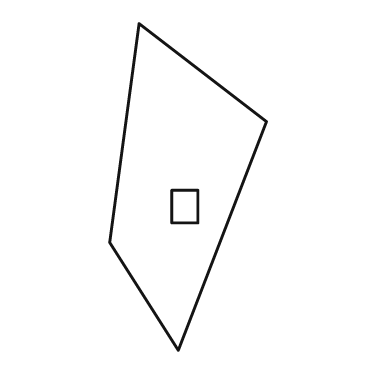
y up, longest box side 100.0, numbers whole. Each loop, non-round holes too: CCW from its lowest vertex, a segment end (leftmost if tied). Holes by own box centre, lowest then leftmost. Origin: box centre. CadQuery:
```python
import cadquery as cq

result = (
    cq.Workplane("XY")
    .moveTo(-3.0, -50.0)
    .lineTo(24.0, 20.0)
    .lineTo(-15.0, 50.0)
    .lineTo(-24.0, -17.0)
    .close()
    .moveTo(-5.0, -11.0)
    .lineTo(3.0, -11.0)
    .lineTo(3.0, -1.0)
    .lineTo(-5.0, -1.0)
    .close()
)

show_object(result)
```